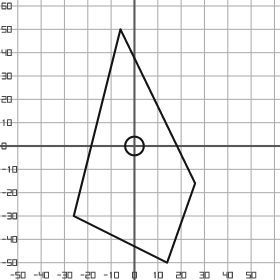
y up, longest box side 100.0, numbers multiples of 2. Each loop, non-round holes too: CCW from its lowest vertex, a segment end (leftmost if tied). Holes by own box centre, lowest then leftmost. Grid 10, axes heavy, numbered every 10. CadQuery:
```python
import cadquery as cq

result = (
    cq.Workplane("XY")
    .moveTo(14.0, -50.0)
    .lineTo(26.0, -16.0)
    .lineTo(-6.0, 50.0)
    .lineTo(-26.0, -30.0)
    .close()
    .moveTo(0.0, 0.0)
    .circle(4.0)
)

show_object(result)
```